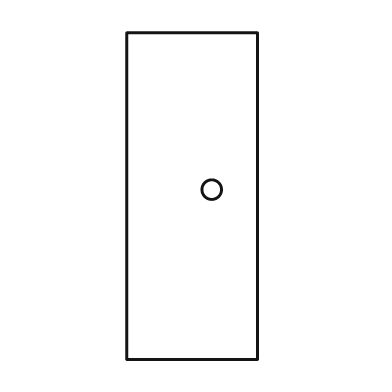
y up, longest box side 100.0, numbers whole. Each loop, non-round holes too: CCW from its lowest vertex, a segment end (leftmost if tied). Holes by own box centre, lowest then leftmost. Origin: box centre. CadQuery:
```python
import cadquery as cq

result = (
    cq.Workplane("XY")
    .moveTo(-20.0, -50.0)
    .lineTo(20.0, -50.0)
    .lineTo(20.0, 50.0)
    .lineTo(-20.0, 50.0)
    .close()
    .moveTo(6.0, 2.0)
    .circle(3.0)
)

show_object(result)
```